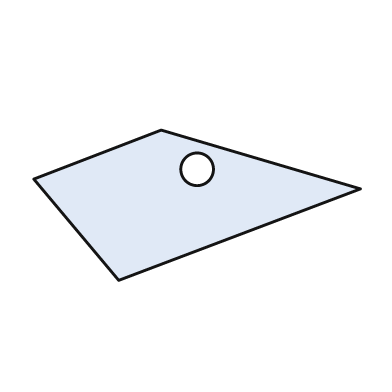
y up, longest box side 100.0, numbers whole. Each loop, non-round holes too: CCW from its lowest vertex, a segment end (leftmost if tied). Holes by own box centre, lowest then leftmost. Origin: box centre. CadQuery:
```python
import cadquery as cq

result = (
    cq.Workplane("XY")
    .moveTo(-24.0, -23.0)
    .lineTo(50.0, 5.0)
    .lineTo(-11.0, 23.0)
    .lineTo(-50.0, 8.0)
    .close()
    .moveTo(0.0, 11.0)
    .circle(5.0)
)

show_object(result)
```